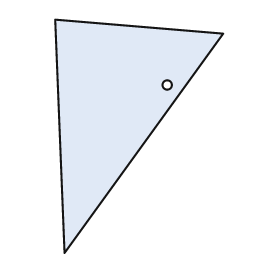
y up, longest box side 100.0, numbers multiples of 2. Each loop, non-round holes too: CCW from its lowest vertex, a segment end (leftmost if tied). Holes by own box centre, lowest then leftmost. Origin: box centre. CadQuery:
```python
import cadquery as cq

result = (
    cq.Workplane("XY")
    .moveTo(-32.0, -50.0)
    .lineTo(36.0, 44.0)
    .lineTo(-36.0, 50.0)
    .close()
    .moveTo(12.0, 22.0)
    .circle(2.0)
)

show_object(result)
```